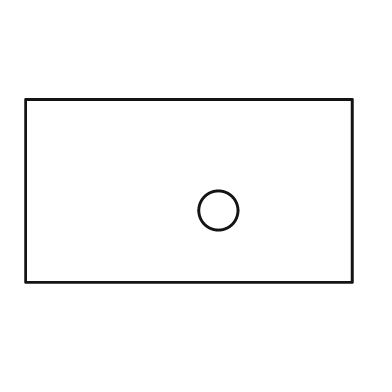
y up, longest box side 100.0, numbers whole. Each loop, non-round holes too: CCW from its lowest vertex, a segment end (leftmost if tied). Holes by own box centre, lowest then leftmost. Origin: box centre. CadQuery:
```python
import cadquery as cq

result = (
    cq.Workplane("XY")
    .moveTo(-50.0, -28.0)
    .lineTo(50.0, -28.0)
    .lineTo(50.0, 28.0)
    .lineTo(-50.0, 28.0)
    .close()
    .moveTo(9.0, -6.0)
    .circle(6.0)
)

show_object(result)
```